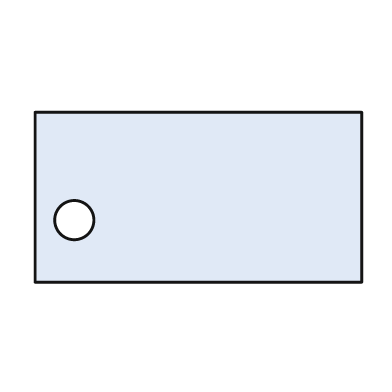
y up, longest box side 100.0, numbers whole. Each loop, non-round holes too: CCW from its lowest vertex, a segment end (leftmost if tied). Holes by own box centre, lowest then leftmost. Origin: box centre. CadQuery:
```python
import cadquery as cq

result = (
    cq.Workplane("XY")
    .moveTo(-50.0, -26.0)
    .lineTo(50.0, -26.0)
    .lineTo(50.0, 26.0)
    .lineTo(-50.0, 26.0)
    .close()
    .moveTo(-38.0, -7.0)
    .circle(6.0)
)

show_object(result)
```